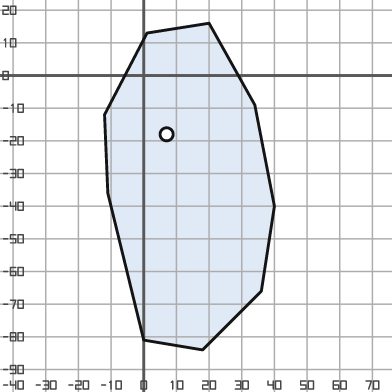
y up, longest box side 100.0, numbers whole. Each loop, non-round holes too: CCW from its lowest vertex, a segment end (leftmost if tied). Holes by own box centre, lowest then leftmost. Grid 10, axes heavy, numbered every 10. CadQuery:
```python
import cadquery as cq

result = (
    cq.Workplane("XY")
    .moveTo(18.0, -84.0)
    .lineTo(36.0, -66.0)
    .lineTo(40.0, -40.0)
    .lineTo(34.0, -9.0)
    .lineTo(20.0, 16.0)
    .lineTo(1.0, 13.0)
    .lineTo(-12.0, -12.0)
    .lineTo(-11.0, -36.0)
    .lineTo(0.0, -81.0)
    .close()
    .moveTo(7.0, -18.0)
    .circle(2.0)
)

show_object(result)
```